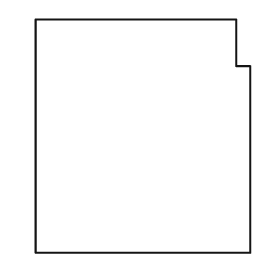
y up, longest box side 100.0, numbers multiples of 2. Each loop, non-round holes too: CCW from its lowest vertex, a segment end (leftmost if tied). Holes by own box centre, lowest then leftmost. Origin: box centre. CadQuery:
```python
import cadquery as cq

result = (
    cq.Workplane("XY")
    .moveTo(-46.0, -50.0)
    .lineTo(46.0, -50.0)
    .lineTo(46.0, 30.0)
    .lineTo(40.0, 30.0)
    .lineTo(40.0, 50.0)
    .lineTo(-46.0, 50.0)
    .close()
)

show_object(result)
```